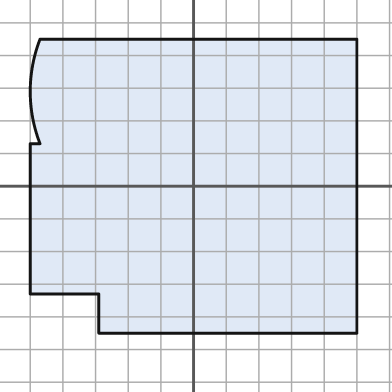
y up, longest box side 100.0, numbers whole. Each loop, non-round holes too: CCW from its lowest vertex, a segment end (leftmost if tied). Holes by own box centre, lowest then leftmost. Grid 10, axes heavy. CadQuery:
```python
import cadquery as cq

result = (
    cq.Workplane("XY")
    .moveTo(-29.0, -45.0)
    .lineTo(50.0, -45.0)
    .lineTo(50.0, 45.0)
    .lineTo(-47.0, 45.0)
    .threePointArc((-50.0, 29.0), (-47.0, 13.0))
    .lineTo(-50.0, 13.0)
    .lineTo(-50.0, -33.0)
    .lineTo(-29.0, -33.0)
    .close()
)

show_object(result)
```